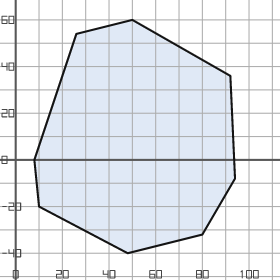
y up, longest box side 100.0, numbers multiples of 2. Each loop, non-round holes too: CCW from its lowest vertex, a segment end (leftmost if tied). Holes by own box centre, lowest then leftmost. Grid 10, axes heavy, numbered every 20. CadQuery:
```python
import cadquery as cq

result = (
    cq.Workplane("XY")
    .moveTo(48.0, -40.0)
    .lineTo(80.0, -32.0)
    .lineTo(94.0, -8.0)
    .lineTo(92.0, 36.0)
    .lineTo(50.0, 60.0)
    .lineTo(26.0, 54.0)
    .lineTo(8.0, 0.0)
    .lineTo(10.0, -20.0)
    .close()
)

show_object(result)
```